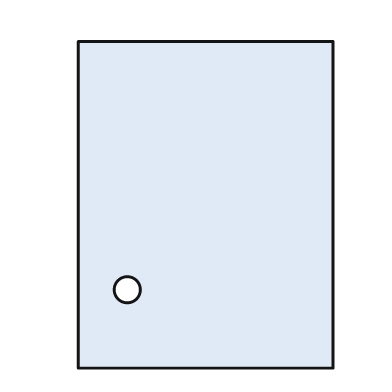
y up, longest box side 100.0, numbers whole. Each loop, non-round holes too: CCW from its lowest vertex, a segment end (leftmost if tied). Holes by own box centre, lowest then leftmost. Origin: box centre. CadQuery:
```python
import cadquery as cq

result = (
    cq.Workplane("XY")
    .moveTo(-39.0, -50.0)
    .lineTo(39.0, -50.0)
    .lineTo(39.0, 50.0)
    .lineTo(-39.0, 50.0)
    .close()
    .moveTo(-24.0, -26.0)
    .circle(4.0)
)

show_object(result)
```